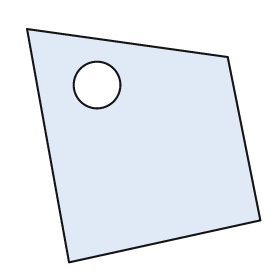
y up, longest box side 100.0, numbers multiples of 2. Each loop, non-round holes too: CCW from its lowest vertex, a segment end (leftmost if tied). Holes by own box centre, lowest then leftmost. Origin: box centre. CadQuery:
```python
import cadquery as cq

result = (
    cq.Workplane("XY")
    .moveTo(-32.0, -50.0)
    .lineTo(50.0, -32.0)
    .lineTo(36.0, 38.0)
    .lineTo(-50.0, 50.0)
    .close()
    .moveTo(-20.0, 26.0)
    .circle(10.0)
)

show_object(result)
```